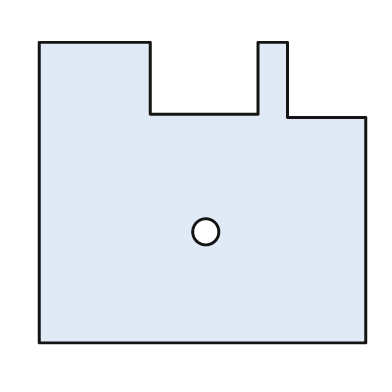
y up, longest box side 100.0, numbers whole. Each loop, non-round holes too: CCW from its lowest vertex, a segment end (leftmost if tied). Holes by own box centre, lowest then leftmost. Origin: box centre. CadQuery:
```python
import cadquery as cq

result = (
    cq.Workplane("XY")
    .moveTo(-50.0, -46.0)
    .lineTo(50.0, -46.0)
    .lineTo(50.0, 23.0)
    .lineTo(26.0, 23.0)
    .lineTo(26.0, 46.0)
    .lineTo(17.0, 46.0)
    .lineTo(17.0, 24.0)
    .lineTo(-16.0, 24.0)
    .lineTo(-16.0, 46.0)
    .lineTo(-50.0, 46.0)
    .close()
    .moveTo(1.0, -12.0)
    .circle(4.0)
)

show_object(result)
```